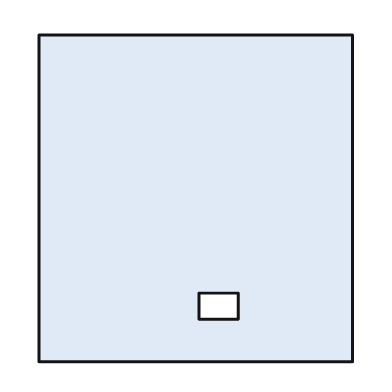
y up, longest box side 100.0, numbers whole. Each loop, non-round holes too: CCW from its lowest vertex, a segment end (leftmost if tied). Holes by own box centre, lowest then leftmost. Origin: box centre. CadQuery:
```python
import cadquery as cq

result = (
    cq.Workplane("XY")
    .moveTo(-48.0, -50.0)
    .lineTo(48.0, -50.0)
    .lineTo(48.0, 50.0)
    .lineTo(-48.0, 50.0)
    .close()
    .moveTo(1.0, -37.0)
    .lineTo(13.0, -37.0)
    .lineTo(13.0, -29.0)
    .lineTo(1.0, -29.0)
    .close()
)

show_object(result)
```